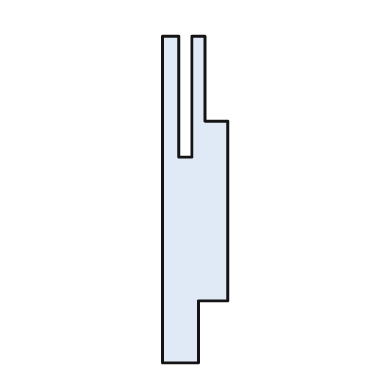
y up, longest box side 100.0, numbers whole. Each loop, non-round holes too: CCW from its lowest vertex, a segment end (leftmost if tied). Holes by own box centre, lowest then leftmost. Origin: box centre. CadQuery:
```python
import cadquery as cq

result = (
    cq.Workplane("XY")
    .moveTo(-10.0, -50.0)
    .lineTo(1.0, -50.0)
    .lineTo(1.0, -31.0)
    .lineTo(10.0, -31.0)
    .lineTo(10.0, 24.0)
    .lineTo(3.0, 24.0)
    .lineTo(3.0, 50.0)
    .lineTo(-1.0, 50.0)
    .lineTo(-1.0, 13.0)
    .lineTo(-5.0, 13.0)
    .lineTo(-5.0, 50.0)
    .lineTo(-10.0, 50.0)
    .close()
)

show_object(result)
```